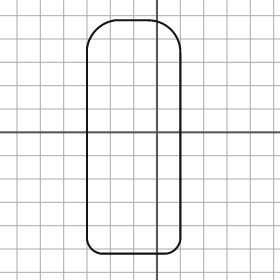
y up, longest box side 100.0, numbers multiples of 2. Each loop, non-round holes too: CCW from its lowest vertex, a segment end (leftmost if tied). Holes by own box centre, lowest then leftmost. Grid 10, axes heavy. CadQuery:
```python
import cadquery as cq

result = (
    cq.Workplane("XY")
    .moveTo(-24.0, -52.0)
    .lineTo(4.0, -52.0)
    .threePointArc((8.0, -50.0), (10.0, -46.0))
    .lineTo(10.0, 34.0)
    .threePointArc((6.0, 44.0), (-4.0, 48.0))
    .lineTo(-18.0, 48.0)
    .threePointArc((-26.0, 44.0), (-30.0, 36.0))
    .lineTo(-30.0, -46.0)
    .threePointArc((-28.0, -50.0), (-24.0, -52.0))
    .close()
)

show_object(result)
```